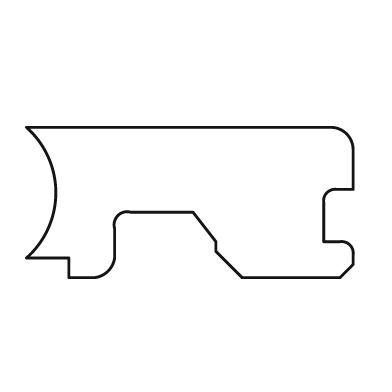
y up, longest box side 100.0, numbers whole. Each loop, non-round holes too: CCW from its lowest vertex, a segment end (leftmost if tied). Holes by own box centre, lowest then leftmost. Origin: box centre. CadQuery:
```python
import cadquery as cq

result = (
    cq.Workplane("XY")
    .moveTo(-37.0, -23.0)
    .lineTo(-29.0, -23.0)
    .threePointArc((-25.0, -21.0), (-23.0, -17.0))
    .lineTo(-23.0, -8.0)
    .threePointArc((-22.0, -4.0), (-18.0, -3.0))
    .lineTo(1.0, -3.0)
    .lineTo(8.0, -12.0)
    .lineTo(8.0, -15.0)
    .lineTo(16.0, -23.0)
    .lineTo(46.0, -23.0)
    .lineTo(50.0, -19.0)
    .lineTo(50.0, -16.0)
    .threePointArc((49.0, -13.0), (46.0, -12.0))
    .lineTo(41.0, -12.0)
    .lineTo(41.0, 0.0)
    .threePointArc((42.0, 3.0), (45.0, 4.0))
    .lineTo(50.0, 4.0)
    .lineTo(50.0, 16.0)
    .threePointArc((48.0, 21.0), (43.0, 23.0))
    .lineTo(-50.0, 23.0)
    .threePointArc((-41.0, 3.0), (-50.0, -17.0))
    .lineTo(-37.0, -17.0)
    .close()
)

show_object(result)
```